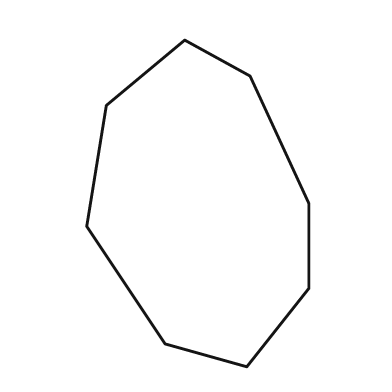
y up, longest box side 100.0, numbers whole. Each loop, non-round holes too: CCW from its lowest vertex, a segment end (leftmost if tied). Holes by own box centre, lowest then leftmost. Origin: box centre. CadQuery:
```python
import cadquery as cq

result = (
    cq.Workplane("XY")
    .moveTo(15.0, -50.0)
    .lineTo(34.0, -26.0)
    .lineTo(34.0, 0.0)
    .lineTo(16.0, 39.0)
    .lineTo(-4.0, 50.0)
    .lineTo(-28.0, 30.0)
    .lineTo(-34.0, -7.0)
    .lineTo(-10.0, -43.0)
    .close()
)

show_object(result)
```